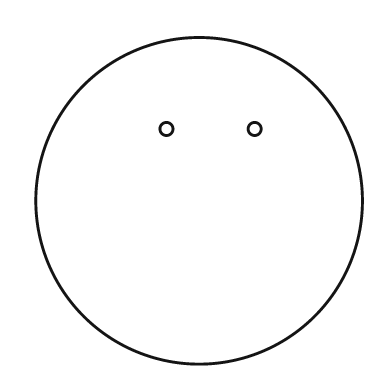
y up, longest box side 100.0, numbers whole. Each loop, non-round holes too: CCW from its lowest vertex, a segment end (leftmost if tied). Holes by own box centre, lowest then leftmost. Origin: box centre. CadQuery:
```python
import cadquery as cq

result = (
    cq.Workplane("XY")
    .moveTo(0.0, 0.0)
    .circle(50.0)
    .moveTo(-10.0, 22.0)
    .circle(2.0)
    .moveTo(17.0, 22.0)
    .circle(2.0)
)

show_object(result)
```